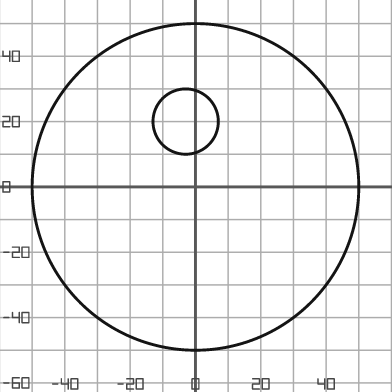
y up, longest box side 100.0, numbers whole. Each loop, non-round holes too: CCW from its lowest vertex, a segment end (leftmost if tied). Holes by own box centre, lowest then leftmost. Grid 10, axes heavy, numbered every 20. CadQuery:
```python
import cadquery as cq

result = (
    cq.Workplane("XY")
    .moveTo(0.0, 0.0)
    .circle(50.0)
    .moveTo(-3.0, 20.0)
    .circle(10.0)
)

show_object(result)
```